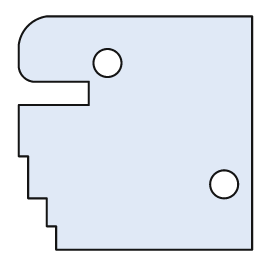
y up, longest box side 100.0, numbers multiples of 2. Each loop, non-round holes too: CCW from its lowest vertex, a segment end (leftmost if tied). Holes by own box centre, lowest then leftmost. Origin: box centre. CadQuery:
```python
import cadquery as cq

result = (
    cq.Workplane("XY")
    .moveTo(-34.0, -50.0)
    .lineTo(50.0, -50.0)
    .lineTo(50.0, 50.0)
    .lineTo(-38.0, 50.0)
    .threePointArc((-46.0, 46.0), (-50.0, 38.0))
    .lineTo(-50.0, 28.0)
    .threePointArc((-48.0, 24.0), (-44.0, 22.0))
    .lineTo(-20.0, 22.0)
    .lineTo(-20.0, 12.0)
    .lineTo(-50.0, 12.0)
    .lineTo(-50.0, -10.0)
    .lineTo(-46.0, -10.0)
    .lineTo(-46.0, -28.0)
    .lineTo(-38.0, -28.0)
    .lineTo(-38.0, -40.0)
    .lineTo(-34.0, -40.0)
    .close()
    .moveTo(38.0, -22.0)
    .circle(6.0)
    .moveTo(-12.0, 30.0)
    .circle(6.0)
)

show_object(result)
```